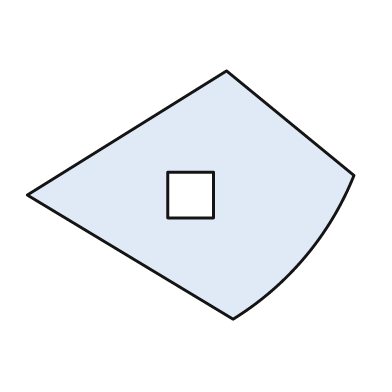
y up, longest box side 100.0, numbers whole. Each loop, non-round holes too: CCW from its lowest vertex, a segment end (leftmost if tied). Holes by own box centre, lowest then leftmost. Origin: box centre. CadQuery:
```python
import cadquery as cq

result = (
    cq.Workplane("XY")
    .moveTo(13.0, -38.0)
    .threePointArc((35.0, -19.0), (50.0, 6.0))
    .lineTo(11.0, 38.0)
    .lineTo(-50.0, 0.0)
    .close()
    .moveTo(-7.0, -7.0)
    .lineTo(7.0, -7.0)
    .lineTo(7.0, 7.0)
    .lineTo(-7.0, 7.0)
    .close()
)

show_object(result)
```